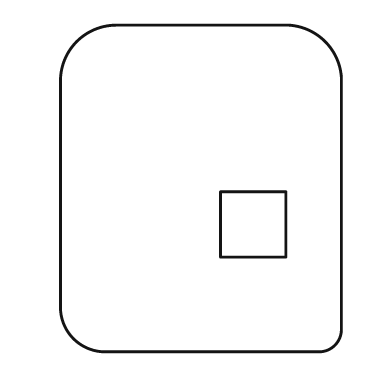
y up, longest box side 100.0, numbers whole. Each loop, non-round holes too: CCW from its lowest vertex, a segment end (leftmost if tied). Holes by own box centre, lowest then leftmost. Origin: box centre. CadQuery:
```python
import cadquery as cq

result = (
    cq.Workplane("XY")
    .moveTo(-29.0, -50.0)
    .lineTo(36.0, -50.0)
    .threePointArc((41.0, -48.0), (43.0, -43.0))
    .lineTo(43.0, 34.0)
    .threePointArc((38.0, 45.0), (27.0, 50.0))
    .lineTo(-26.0, 50.0)
    .threePointArc((-38.0, 45.0), (-43.0, 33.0))
    .lineTo(-43.0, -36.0)
    .threePointArc((-39.0, -46.0), (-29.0, -50.0))
    .close()
    .moveTo(6.0, -21.0)
    .lineTo(26.0, -21.0)
    .lineTo(26.0, -1.0)
    .lineTo(6.0, -1.0)
    .close()
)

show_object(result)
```